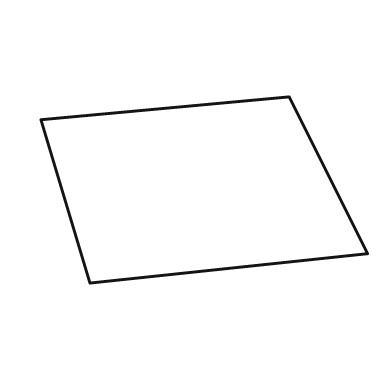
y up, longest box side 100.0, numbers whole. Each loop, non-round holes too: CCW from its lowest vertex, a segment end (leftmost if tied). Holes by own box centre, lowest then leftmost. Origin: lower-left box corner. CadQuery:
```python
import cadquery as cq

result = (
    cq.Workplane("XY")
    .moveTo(15.0, 0.0)
    .lineTo(100.0, 9.0)
    .lineTo(76.0, 57.0)
    .lineTo(0.0, 50.0)
    .close()
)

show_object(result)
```